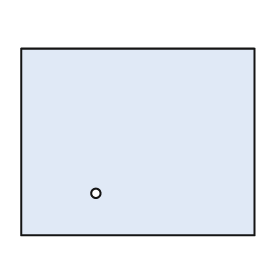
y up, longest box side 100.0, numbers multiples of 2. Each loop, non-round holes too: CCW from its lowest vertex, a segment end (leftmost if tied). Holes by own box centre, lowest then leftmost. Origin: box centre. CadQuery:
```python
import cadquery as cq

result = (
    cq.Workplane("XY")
    .moveTo(-50.0, -40.0)
    .lineTo(50.0, -40.0)
    .lineTo(50.0, 40.0)
    .lineTo(-50.0, 40.0)
    .close()
    .moveTo(-18.0, -22.0)
    .circle(2.0)
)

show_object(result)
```